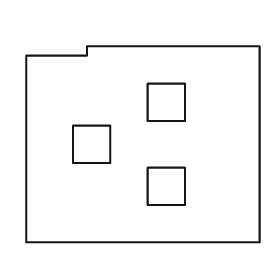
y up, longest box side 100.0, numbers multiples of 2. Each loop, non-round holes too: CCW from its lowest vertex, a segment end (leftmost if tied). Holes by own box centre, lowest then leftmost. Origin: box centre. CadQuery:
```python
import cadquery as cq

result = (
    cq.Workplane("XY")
    .moveTo(-50.0, -42.0)
    .lineTo(50.0, -42.0)
    .lineTo(50.0, 42.0)
    .lineTo(-24.0, 42.0)
    .lineTo(-24.0, 38.0)
    .lineTo(-50.0, 38.0)
    .close()
    .moveTo(2.0, -26.0)
    .lineTo(18.0, -26.0)
    .lineTo(18.0, -10.0)
    .lineTo(2.0, -10.0)
    .close()
    .moveTo(-30.0, -8.0)
    .lineTo(-14.0, -8.0)
    .lineTo(-14.0, 8.0)
    .lineTo(-30.0, 8.0)
    .close()
    .moveTo(2.0, 10.0)
    .lineTo(18.0, 10.0)
    .lineTo(18.0, 26.0)
    .lineTo(2.0, 26.0)
    .close()
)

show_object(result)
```